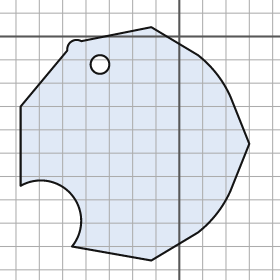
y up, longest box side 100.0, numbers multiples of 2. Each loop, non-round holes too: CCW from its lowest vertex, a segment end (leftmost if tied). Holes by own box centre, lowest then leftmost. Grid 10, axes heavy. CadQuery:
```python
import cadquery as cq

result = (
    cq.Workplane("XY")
    .moveTo(-12.0, -96.0)
    .lineTo(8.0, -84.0)
    .threePointArc((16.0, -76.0), (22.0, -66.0))
    .lineTo(30.0, -46.0)
    .lineTo(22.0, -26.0)
    .threePointArc((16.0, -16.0), (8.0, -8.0))
    .lineTo(-12.0, 4.0)
    .lineTo(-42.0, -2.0)
    .threePointArc((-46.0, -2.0), (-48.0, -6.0))
    .lineTo(-68.0, -30.0)
    .lineTo(-68.0, -64.0)
    .threePointArc((-46.0, -68.0), (-46.0, -90.0))
    .close()
    .moveTo(-34.0, -12.0)
    .circle(4.0)
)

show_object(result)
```